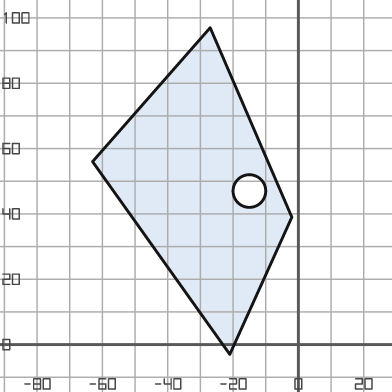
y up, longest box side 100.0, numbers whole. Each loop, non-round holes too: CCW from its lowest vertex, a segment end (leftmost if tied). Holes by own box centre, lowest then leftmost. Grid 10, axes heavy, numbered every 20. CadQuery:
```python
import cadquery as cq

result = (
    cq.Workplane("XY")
    .moveTo(-21.0, -3.0)
    .lineTo(-2.0, 39.0)
    .lineTo(-27.0, 97.0)
    .lineTo(-63.0, 56.0)
    .close()
    .moveTo(-15.0, 47.0)
    .circle(5.0)
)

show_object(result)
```